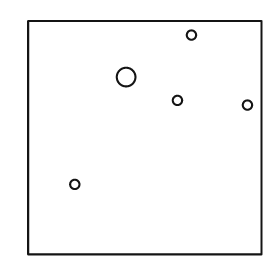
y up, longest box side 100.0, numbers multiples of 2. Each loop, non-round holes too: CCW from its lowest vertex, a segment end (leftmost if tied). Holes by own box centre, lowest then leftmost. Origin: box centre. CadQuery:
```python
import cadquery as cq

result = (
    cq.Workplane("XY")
    .moveTo(-50.0, -50.0)
    .lineTo(50.0, -50.0)
    .lineTo(50.0, 50.0)
    .lineTo(-50.0, 50.0)
    .close()
    .moveTo(-30.0, -20.0)
    .circle(2.0)
    .moveTo(44.0, 14.0)
    .circle(2.0)
    .moveTo(14.0, 16.0)
    .circle(2.0)
    .moveTo(-8.0, 26.0)
    .circle(4.0)
    .moveTo(20.0, 44.0)
    .circle(2.0)
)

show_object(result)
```